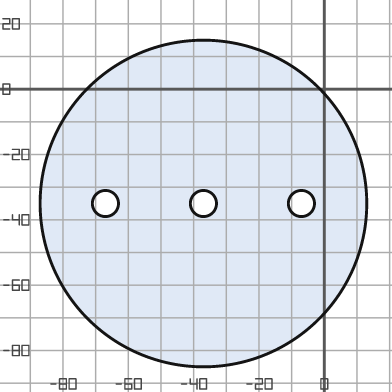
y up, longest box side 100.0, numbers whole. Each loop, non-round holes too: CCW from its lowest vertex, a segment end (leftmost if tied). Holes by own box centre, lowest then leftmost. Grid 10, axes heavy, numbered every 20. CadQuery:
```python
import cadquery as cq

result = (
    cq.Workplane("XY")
    .moveTo(-37.0, -35.0)
    .circle(50.0)
    .moveTo(-67.0, -35.0)
    .circle(4.0)
    .moveTo(-37.0, -35.0)
    .circle(4.0)
    .moveTo(-7.0, -35.0)
    .circle(4.0)
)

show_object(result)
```